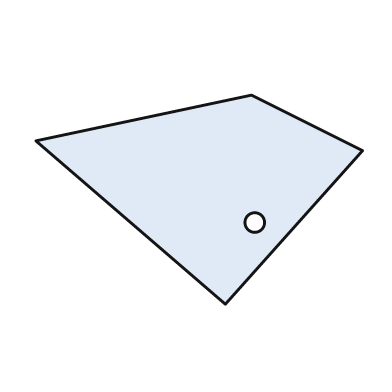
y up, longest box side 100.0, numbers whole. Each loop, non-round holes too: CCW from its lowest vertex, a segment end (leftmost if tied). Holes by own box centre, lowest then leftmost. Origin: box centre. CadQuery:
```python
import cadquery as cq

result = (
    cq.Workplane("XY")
    .moveTo(8.0, -32.0)
    .lineTo(50.0, 15.0)
    .lineTo(16.0, 32.0)
    .lineTo(-50.0, 18.0)
    .close()
    .moveTo(17.0, -7.0)
    .circle(3.0)
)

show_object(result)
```